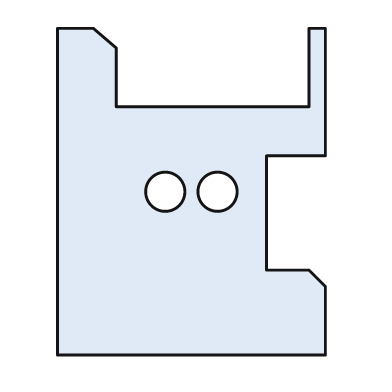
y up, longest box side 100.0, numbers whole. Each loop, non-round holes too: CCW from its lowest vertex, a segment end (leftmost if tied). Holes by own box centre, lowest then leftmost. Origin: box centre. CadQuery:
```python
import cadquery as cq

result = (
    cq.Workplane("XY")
    .moveTo(-41.0, -50.0)
    .lineTo(41.0, -50.0)
    .lineTo(41.0, -29.0)
    .lineTo(36.0, -24.0)
    .lineTo(23.0, -24.0)
    .lineTo(23.0, 11.0)
    .lineTo(41.0, 11.0)
    .lineTo(41.0, 50.0)
    .lineTo(36.0, 50.0)
    .lineTo(36.0, 26.0)
    .lineTo(-23.0, 26.0)
    .lineTo(-23.0, 44.0)
    .lineTo(-30.0, 50.0)
    .lineTo(-41.0, 50.0)
    .close()
    .moveTo(-8.0, 0.0)
    .circle(6.0)
    .moveTo(8.0, 0.0)
    .circle(6.0)
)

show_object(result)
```